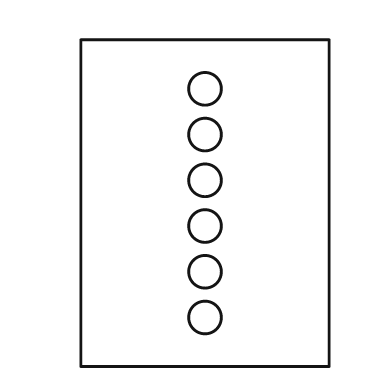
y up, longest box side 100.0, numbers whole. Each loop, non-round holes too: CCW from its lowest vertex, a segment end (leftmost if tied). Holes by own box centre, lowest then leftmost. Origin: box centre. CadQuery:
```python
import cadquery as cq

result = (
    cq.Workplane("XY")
    .moveTo(-38.0, -50.0)
    .lineTo(38.0, -50.0)
    .lineTo(38.0, 50.0)
    .lineTo(-38.0, 50.0)
    .close()
    .moveTo(0.0, -35.0)
    .circle(5.0)
    .moveTo(0.0, -21.0)
    .circle(5.0)
    .moveTo(0.0, -7.0)
    .circle(5.0)
    .moveTo(0.0, 7.0)
    .circle(5.0)
    .moveTo(0.0, 21.0)
    .circle(5.0)
    .moveTo(0.0, 35.0)
    .circle(5.0)
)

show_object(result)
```